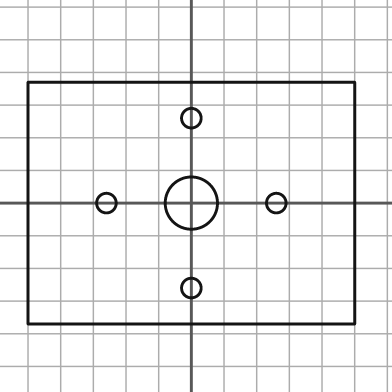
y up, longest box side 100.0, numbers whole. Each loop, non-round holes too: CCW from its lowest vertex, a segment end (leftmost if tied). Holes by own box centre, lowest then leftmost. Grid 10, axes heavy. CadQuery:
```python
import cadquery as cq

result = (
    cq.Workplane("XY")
    .moveTo(-50.0, -37.0)
    .lineTo(50.0, -37.0)
    .lineTo(50.0, 37.0)
    .lineTo(-50.0, 37.0)
    .close()
    .moveTo(0.0, -26.0)
    .circle(3.0)
    .moveTo(-26.0, 0.0)
    .circle(3.0)
    .moveTo(0.0, 0.0)
    .circle(8.0)
    .moveTo(26.0, 0.0)
    .circle(3.0)
    .moveTo(0.0, 26.0)
    .circle(3.0)
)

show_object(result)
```